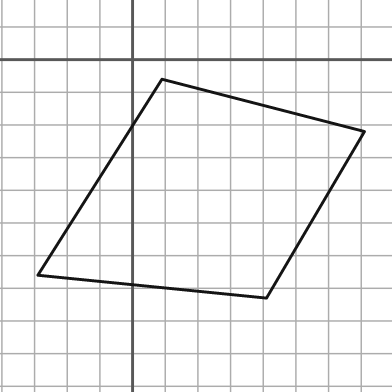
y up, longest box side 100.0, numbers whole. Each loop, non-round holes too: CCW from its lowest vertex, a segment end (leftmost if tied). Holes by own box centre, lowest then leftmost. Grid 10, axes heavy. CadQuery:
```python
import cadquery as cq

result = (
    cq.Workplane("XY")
    .moveTo(41.0, -73.0)
    .lineTo(71.0, -22.0)
    .lineTo(9.0, -6.0)
    .lineTo(-29.0, -66.0)
    .close()
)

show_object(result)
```